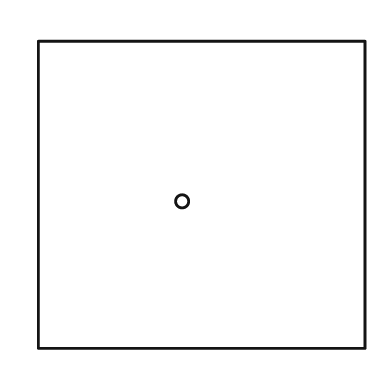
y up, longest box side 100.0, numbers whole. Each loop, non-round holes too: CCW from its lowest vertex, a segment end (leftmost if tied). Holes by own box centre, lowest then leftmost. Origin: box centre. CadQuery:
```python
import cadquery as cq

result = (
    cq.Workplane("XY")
    .moveTo(-50.0, -47.0)
    .lineTo(50.0, -47.0)
    .lineTo(50.0, 47.0)
    .lineTo(-50.0, 47.0)
    .close()
    .moveTo(-6.0, -2.0)
    .circle(2.0)
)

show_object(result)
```